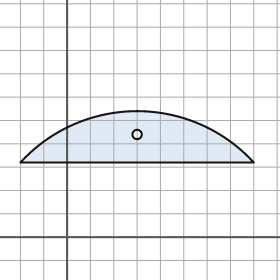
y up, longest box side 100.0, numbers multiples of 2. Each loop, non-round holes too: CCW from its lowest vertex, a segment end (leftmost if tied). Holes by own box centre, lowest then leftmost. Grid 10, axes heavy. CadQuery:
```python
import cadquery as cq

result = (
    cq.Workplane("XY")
    .moveTo(-20.0, 32.0)
    .lineTo(80.0, 32.0)
    .threePointArc((30.0, 54.0), (-20.0, 32.0))
    .close()
    .moveTo(30.0, 44.0)
    .circle(2.0)
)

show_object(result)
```